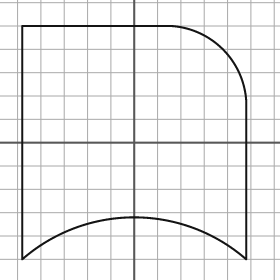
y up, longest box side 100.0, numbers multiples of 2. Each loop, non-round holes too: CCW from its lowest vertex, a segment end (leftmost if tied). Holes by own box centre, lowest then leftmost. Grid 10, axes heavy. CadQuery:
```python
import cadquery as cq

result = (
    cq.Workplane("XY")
    .moveTo(-48.0, -50.0)
    .threePointArc((0.0, -32.0), (48.0, -50.0))
    .lineTo(48.0, 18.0)
    .threePointArc((38.0, 40.0), (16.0, 50.0))
    .lineTo(-48.0, 50.0)
    .close()
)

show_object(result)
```